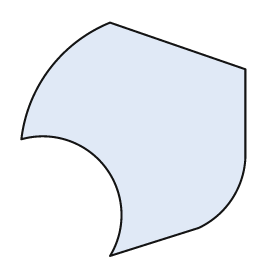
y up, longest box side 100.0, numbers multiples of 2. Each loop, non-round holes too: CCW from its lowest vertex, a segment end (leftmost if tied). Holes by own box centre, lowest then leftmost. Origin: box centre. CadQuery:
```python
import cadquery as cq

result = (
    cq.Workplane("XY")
    .moveTo(-10.0, -50.0)
    .lineTo(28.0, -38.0)
    .threePointArc((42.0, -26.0), (48.0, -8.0))
    .lineTo(48.0, 30.0)
    .lineTo(-10.0, 50.0)
    .threePointArc((-36.0, 30.0), (-48.0, 0.0))
    .threePointArc((-12.0, -12.0), (-10.0, -50.0))
    .close()
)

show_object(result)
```